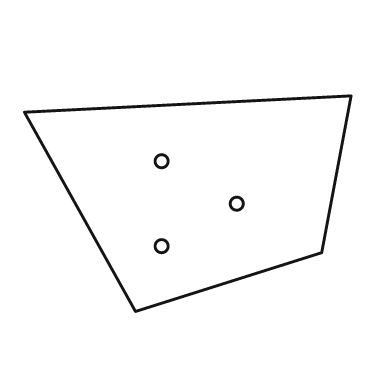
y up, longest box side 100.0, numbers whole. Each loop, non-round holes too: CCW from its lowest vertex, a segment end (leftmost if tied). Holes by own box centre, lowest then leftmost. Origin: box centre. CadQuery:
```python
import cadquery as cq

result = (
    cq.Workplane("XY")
    .moveTo(-16.0, -33.0)
    .lineTo(41.0, -15.0)
    .lineTo(50.0, 33.0)
    .lineTo(-50.0, 28.0)
    .close()
    .moveTo(-8.0, -13.0)
    .circle(2.0)
    .moveTo(15.0, 0.0)
    .circle(2.0)
    .moveTo(-8.0, 13.0)
    .circle(2.0)
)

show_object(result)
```